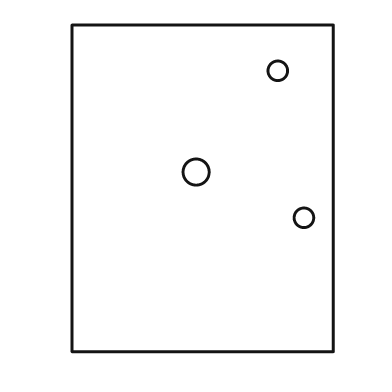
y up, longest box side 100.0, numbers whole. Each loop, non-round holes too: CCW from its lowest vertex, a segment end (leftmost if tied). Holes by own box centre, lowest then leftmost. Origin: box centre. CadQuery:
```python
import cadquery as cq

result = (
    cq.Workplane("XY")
    .moveTo(-40.0, -50.0)
    .lineTo(40.0, -50.0)
    .lineTo(40.0, 50.0)
    .lineTo(-40.0, 50.0)
    .close()
    .moveTo(31.0, -9.0)
    .circle(3.0)
    .moveTo(-2.0, 5.0)
    .circle(4.0)
    .moveTo(23.0, 36.0)
    .circle(3.0)
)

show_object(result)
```